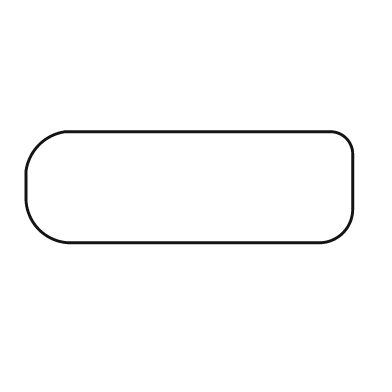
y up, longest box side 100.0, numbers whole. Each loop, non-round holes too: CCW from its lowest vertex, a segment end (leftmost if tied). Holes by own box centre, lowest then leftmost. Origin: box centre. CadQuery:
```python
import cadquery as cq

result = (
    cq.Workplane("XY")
    .moveTo(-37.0, -17.0)
    .lineTo(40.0, -17.0)
    .threePointArc((47.0, -14.0), (50.0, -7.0))
    .lineTo(50.0, 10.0)
    .threePointArc((48.0, 15.0), (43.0, 17.0))
    .lineTo(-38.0, 17.0)
    .threePointArc((-46.0, 13.0), (-50.0, 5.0))
    .lineTo(-50.0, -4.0)
    .threePointArc((-46.0, -13.0), (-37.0, -17.0))
    .close()
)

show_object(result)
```